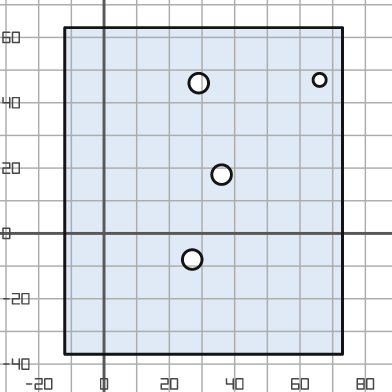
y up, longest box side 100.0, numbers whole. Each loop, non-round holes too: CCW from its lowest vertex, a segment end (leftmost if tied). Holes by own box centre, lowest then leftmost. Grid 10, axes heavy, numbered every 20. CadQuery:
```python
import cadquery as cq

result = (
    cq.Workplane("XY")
    .moveTo(-12.0, -37.0)
    .lineTo(73.0, -37.0)
    .lineTo(73.0, 63.0)
    .lineTo(-12.0, 63.0)
    .close()
    .moveTo(27.0, -8.0)
    .circle(3.0)
    .moveTo(36.0, 18.0)
    .circle(3.0)
    .moveTo(29.0, 46.0)
    .circle(3.0)
    .moveTo(66.0, 47.0)
    .circle(2.0)
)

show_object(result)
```